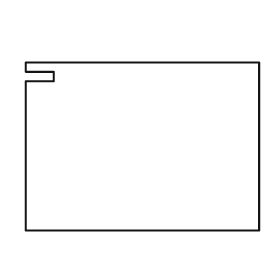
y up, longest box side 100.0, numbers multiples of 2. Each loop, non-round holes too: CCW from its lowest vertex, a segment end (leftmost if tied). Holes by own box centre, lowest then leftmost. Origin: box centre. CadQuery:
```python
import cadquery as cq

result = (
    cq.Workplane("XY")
    .moveTo(-50.0, -36.0)
    .lineTo(50.0, -36.0)
    .lineTo(50.0, 36.0)
    .lineTo(-50.0, 36.0)
    .lineTo(-50.0, 32.0)
    .lineTo(-38.0, 32.0)
    .lineTo(-38.0, 28.0)
    .lineTo(-50.0, 28.0)
    .close()
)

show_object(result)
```